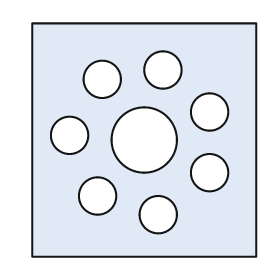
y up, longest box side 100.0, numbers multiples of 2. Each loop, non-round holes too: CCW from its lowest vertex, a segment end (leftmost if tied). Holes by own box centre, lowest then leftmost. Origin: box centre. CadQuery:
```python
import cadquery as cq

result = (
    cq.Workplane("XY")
    .moveTo(-48.0, -50.0)
    .lineTo(48.0, -50.0)
    .lineTo(48.0, 50.0)
    .lineTo(-48.0, 50.0)
    .close()
    .moveTo(6.0, -32.0)
    .circle(8.0)
    .moveTo(-20.0, -24.0)
    .circle(8.0)
    .moveTo(28.0, -14.0)
    .circle(8.0)
    .moveTo(0.0, 0.0)
    .circle(14.0)
    .moveTo(-32.0, 2.0)
    .circle(8.0)
    .moveTo(28.0, 12.0)
    .circle(8.0)
    .moveTo(-18.0, 26.0)
    .circle(8.0)
    .moveTo(8.0, 30.0)
    .circle(8.0)
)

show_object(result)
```